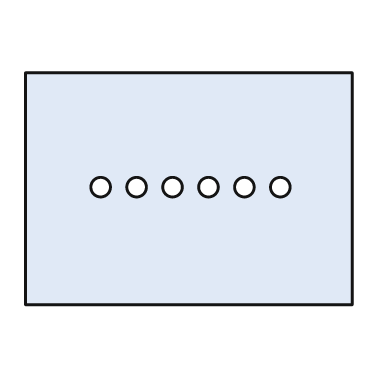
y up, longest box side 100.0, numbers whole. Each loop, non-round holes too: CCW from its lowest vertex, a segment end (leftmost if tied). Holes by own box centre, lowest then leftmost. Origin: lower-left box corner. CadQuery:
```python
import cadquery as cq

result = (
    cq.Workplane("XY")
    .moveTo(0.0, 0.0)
    .lineTo(100.0, 0.0)
    .lineTo(100.0, 71.0)
    .lineTo(0.0, 71.0)
    .close()
    .moveTo(23.0, 36.0)
    .circle(3.0)
    .moveTo(34.0, 36.0)
    .circle(3.0)
    .moveTo(45.0, 36.0)
    .circle(3.0)
    .moveTo(56.0, 36.0)
    .circle(3.0)
    .moveTo(67.0, 36.0)
    .circle(3.0)
    .moveTo(78.0, 36.0)
    .circle(3.0)
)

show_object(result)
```